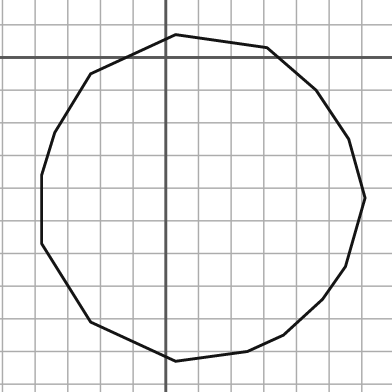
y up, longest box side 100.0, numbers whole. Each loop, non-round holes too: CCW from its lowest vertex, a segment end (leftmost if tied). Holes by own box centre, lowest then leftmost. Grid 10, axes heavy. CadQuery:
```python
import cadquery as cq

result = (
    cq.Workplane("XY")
    .moveTo(3.0, -93.0)
    .lineTo(25.0, -90.0)
    .lineTo(36.0, -85.0)
    .lineTo(48.0, -74.0)
    .lineTo(55.0, -64.0)
    .lineTo(61.0, -43.0)
    .lineTo(56.0, -25.0)
    .lineTo(46.0, -10.0)
    .lineTo(31.0, 3.0)
    .lineTo(3.0, 7.0)
    .lineTo(-23.0, -5.0)
    .lineTo(-34.0, -23.0)
    .lineTo(-38.0, -36.0)
    .lineTo(-38.0, -57.0)
    .lineTo(-23.0, -81.0)
    .close()
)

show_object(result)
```